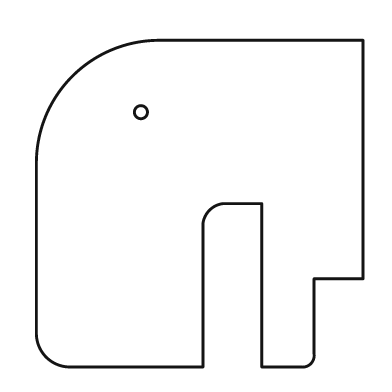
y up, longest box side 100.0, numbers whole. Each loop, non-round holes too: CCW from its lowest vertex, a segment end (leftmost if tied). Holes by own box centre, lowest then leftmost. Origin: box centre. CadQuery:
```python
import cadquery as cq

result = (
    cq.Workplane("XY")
    .moveTo(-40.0, -50.0)
    .lineTo(1.0, -50.0)
    .lineTo(1.0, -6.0)
    .threePointArc((3.0, -2.0), (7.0, 0.0))
    .lineTo(19.0, 0.0)
    .lineTo(19.0, -50.0)
    .lineTo(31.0, -50.0)
    .threePointArc((34.0, -49.0), (35.0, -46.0))
    .lineTo(35.0, -23.0)
    .lineTo(50.0, -23.0)
    .lineTo(50.0, 50.0)
    .lineTo(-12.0, 50.0)
    .threePointArc((-39.0, 39.0), (-50.0, 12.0))
    .lineTo(-50.0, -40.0)
    .threePointArc((-47.0, -47.0), (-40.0, -50.0))
    .close()
    .moveTo(-18.0, 28.0)
    .circle(2.0)
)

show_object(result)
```